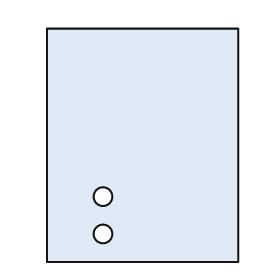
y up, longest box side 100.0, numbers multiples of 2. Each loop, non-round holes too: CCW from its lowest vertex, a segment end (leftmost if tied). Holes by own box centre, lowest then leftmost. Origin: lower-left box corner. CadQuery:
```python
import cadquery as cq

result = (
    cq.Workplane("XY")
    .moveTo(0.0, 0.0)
    .lineTo(82.0, 0.0)
    .lineTo(82.0, 100.0)
    .lineTo(0.0, 100.0)
    .close()
    .moveTo(24.0, 12.0)
    .circle(4.0)
    .moveTo(24.0, 28.0)
    .circle(4.0)
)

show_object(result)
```